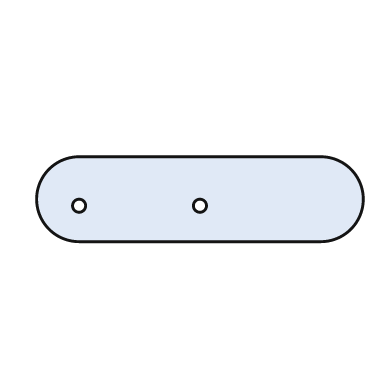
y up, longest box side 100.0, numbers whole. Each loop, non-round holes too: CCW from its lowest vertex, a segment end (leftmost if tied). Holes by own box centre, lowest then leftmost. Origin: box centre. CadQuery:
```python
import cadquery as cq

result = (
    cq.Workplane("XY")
    .moveTo(-37.0, -13.0)
    .lineTo(37.0, -13.0)
    .threePointArc((50.0, 0.0), (37.0, 13.0))
    .lineTo(-37.0, 13.0)
    .threePointArc((-50.0, 0.0), (-37.0, -13.0))
    .close()
    .moveTo(-37.0, -2.0)
    .circle(2.0)
    .moveTo(0.0, -2.0)
    .circle(2.0)
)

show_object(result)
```